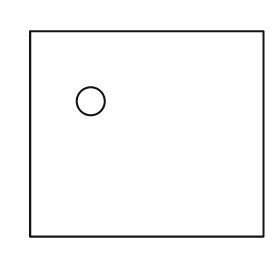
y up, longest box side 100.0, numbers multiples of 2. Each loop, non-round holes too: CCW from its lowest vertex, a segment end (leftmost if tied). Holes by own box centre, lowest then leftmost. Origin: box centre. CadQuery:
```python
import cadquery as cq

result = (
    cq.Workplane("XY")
    .moveTo(-50.0, -44.0)
    .lineTo(50.0, -44.0)
    .lineTo(50.0, 44.0)
    .lineTo(-50.0, 44.0)
    .close()
    .moveTo(-24.0, 14.0)
    .circle(6.0)
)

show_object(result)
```